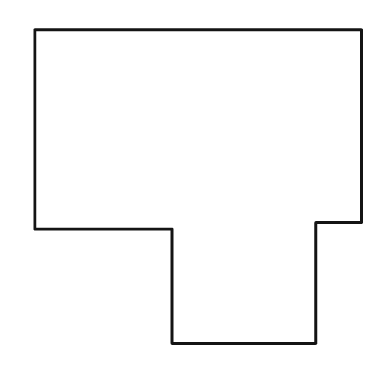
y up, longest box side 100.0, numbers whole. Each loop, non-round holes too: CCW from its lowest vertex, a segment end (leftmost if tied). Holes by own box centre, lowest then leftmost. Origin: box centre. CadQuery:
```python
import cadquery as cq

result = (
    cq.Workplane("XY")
    .moveTo(-8.0, -48.0)
    .lineTo(36.0, -48.0)
    .lineTo(36.0, -11.0)
    .lineTo(50.0, -11.0)
    .lineTo(50.0, 48.0)
    .lineTo(-50.0, 48.0)
    .lineTo(-50.0, -13.0)
    .lineTo(-8.0, -13.0)
    .close()
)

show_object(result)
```